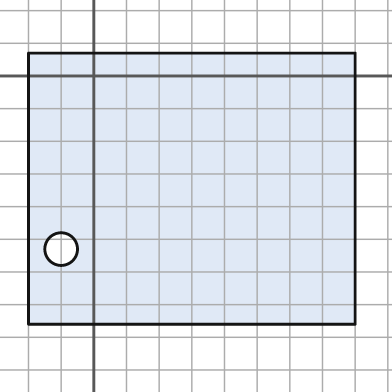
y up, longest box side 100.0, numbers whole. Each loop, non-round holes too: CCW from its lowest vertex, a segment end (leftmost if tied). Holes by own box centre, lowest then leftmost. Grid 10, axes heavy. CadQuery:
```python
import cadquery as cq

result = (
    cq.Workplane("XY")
    .moveTo(-20.0, -76.0)
    .lineTo(80.0, -76.0)
    .lineTo(80.0, 7.0)
    .lineTo(-20.0, 7.0)
    .close()
    .moveTo(-10.0, -53.0)
    .circle(5.0)
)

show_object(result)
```